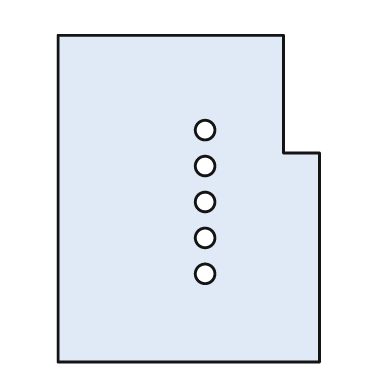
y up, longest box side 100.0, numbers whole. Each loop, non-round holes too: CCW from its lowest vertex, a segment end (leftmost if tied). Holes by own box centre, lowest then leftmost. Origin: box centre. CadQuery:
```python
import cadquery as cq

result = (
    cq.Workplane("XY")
    .moveTo(-40.0, -50.0)
    .lineTo(40.0, -50.0)
    .lineTo(40.0, 14.0)
    .lineTo(29.0, 14.0)
    .lineTo(29.0, 50.0)
    .lineTo(-40.0, 50.0)
    .close()
    .moveTo(5.0, -23.0)
    .circle(3.0)
    .moveTo(5.0, -12.0)
    .circle(3.0)
    .moveTo(5.0, -1.0)
    .circle(3.0)
    .moveTo(5.0, 10.0)
    .circle(3.0)
    .moveTo(5.0, 21.0)
    .circle(3.0)
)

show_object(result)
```